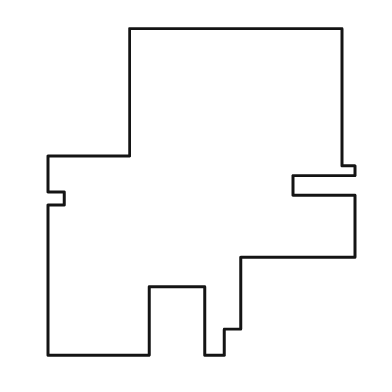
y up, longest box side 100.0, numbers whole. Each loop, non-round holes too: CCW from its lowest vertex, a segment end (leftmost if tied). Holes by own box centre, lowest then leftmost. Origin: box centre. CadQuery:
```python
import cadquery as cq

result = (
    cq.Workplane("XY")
    .moveTo(-47.0, -50.0)
    .lineTo(-16.0, -50.0)
    .lineTo(-16.0, -29.0)
    .lineTo(1.0, -29.0)
    .lineTo(1.0, -50.0)
    .lineTo(7.0, -50.0)
    .lineTo(7.0, -42.0)
    .lineTo(12.0, -42.0)
    .lineTo(12.0, -20.0)
    .lineTo(47.0, -20.0)
    .lineTo(47.0, -1.0)
    .lineTo(28.0, -1.0)
    .lineTo(28.0, 5.0)
    .lineTo(47.0, 5.0)
    .lineTo(47.0, 8.0)
    .lineTo(43.0, 8.0)
    .lineTo(43.0, 50.0)
    .lineTo(-22.0, 50.0)
    .lineTo(-22.0, 11.0)
    .lineTo(-47.0, 11.0)
    .lineTo(-47.0, 0.0)
    .lineTo(-42.0, 0.0)
    .lineTo(-42.0, -4.0)
    .lineTo(-47.0, -4.0)
    .close()
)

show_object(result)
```